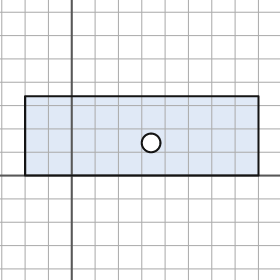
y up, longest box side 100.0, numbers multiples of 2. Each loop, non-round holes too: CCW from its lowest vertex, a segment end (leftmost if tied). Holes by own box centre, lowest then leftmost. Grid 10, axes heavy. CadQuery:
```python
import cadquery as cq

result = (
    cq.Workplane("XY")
    .moveTo(-20.0, 0.0)
    .lineTo(80.0, 0.0)
    .lineTo(80.0, 34.0)
    .lineTo(-20.0, 34.0)
    .close()
    .moveTo(34.0, 14.0)
    .circle(4.0)
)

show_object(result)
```